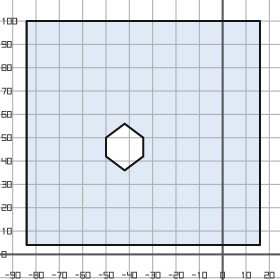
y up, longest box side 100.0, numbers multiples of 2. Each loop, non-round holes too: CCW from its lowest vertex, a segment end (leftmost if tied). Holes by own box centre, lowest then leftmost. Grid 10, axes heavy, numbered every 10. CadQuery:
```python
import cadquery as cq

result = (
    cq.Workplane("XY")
    .moveTo(-84.0, 4.0)
    .lineTo(16.0, 4.0)
    .lineTo(16.0, 100.0)
    .lineTo(-84.0, 100.0)
    .close()
    .moveTo(-42.0, 36.0)
    .lineTo(-34.0, 42.0)
    .lineTo(-34.0, 50.0)
    .lineTo(-42.0, 56.0)
    .lineTo(-50.0, 50.0)
    .lineTo(-50.0, 42.0)
    .close()
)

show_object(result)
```